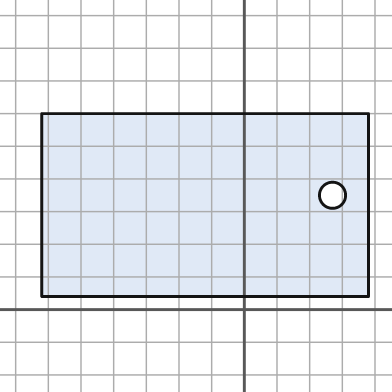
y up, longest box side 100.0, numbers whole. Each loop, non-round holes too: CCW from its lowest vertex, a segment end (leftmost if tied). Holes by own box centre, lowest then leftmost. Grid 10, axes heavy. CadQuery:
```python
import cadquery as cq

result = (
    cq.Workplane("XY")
    .moveTo(-62.0, 4.0)
    .lineTo(38.0, 4.0)
    .lineTo(38.0, 60.0)
    .lineTo(-62.0, 60.0)
    .close()
    .moveTo(27.0, 35.0)
    .circle(4.0)
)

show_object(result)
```